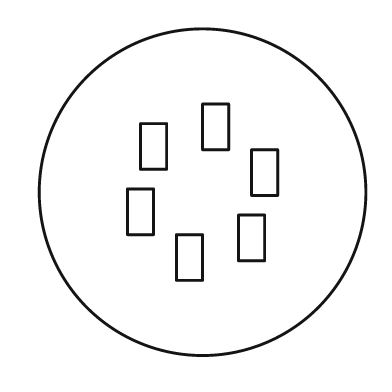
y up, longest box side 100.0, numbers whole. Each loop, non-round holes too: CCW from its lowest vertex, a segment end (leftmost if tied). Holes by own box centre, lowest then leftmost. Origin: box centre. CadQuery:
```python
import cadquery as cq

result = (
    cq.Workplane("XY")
    .moveTo(0.0, 0.0)
    .circle(50.0)
    .moveTo(-8.0, -27.0)
    .lineTo(0.0, -27.0)
    .lineTo(0.0, -13.0)
    .lineTo(-8.0, -13.0)
    .close()
    .moveTo(11.0, -21.0)
    .lineTo(19.0, -21.0)
    .lineTo(19.0, -7.0)
    .lineTo(11.0, -7.0)
    .close()
    .moveTo(-23.0, -13.0)
    .lineTo(-15.0, -13.0)
    .lineTo(-15.0, 1.0)
    .lineTo(-23.0, 1.0)
    .close()
    .moveTo(15.0, -1.0)
    .lineTo(23.0, -1.0)
    .lineTo(23.0, 13.0)
    .lineTo(15.0, 13.0)
    .close()
    .moveTo(-19.0, 7.0)
    .lineTo(-11.0, 7.0)
    .lineTo(-11.0, 21.0)
    .lineTo(-19.0, 21.0)
    .close()
    .moveTo(0.0, 13.0)
    .lineTo(8.0, 13.0)
    .lineTo(8.0, 27.0)
    .lineTo(0.0, 27.0)
    .close()
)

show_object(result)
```